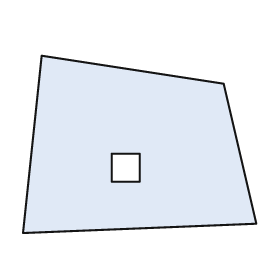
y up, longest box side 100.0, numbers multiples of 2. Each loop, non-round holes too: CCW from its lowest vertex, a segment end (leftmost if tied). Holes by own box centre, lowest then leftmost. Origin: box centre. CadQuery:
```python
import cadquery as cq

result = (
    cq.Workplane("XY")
    .moveTo(-50.0, -38.0)
    .lineTo(50.0, -34.0)
    .lineTo(36.0, 26.0)
    .lineTo(-42.0, 38.0)
    .close()
    .moveTo(-12.0, -16.0)
    .lineTo(0.0, -16.0)
    .lineTo(0.0, -4.0)
    .lineTo(-12.0, -4.0)
    .close()
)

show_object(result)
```